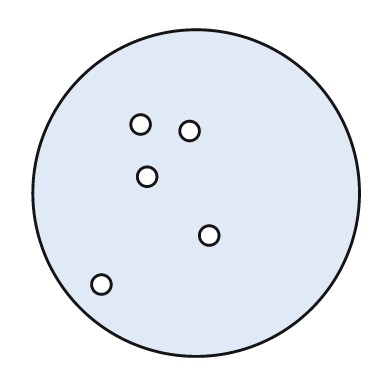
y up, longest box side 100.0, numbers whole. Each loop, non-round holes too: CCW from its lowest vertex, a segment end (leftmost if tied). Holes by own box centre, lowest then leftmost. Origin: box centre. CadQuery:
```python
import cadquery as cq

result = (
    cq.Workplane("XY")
    .moveTo(0.0, 0.0)
    .circle(50.0)
    .moveTo(-29.0, -28.0)
    .circle(3.0)
    .moveTo(4.0, -13.0)
    .circle(3.0)
    .moveTo(-15.0, 5.0)
    .circle(3.0)
    .moveTo(-2.0, 19.0)
    .circle(3.0)
    .moveTo(-17.0, 21.0)
    .circle(3.0)
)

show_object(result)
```